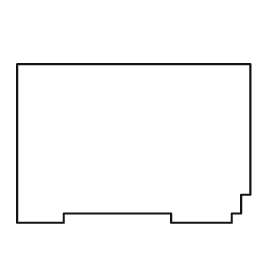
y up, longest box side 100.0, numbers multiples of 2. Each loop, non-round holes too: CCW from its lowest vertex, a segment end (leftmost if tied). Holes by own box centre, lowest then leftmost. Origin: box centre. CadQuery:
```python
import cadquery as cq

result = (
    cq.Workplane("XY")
    .moveTo(-50.0, -34.0)
    .lineTo(-30.0, -34.0)
    .lineTo(-30.0, -30.0)
    .lineTo(16.0, -30.0)
    .lineTo(16.0, -34.0)
    .lineTo(42.0, -34.0)
    .lineTo(42.0, -30.0)
    .lineTo(46.0, -30.0)
    .lineTo(46.0, -22.0)
    .lineTo(50.0, -22.0)
    .lineTo(50.0, 34.0)
    .lineTo(-50.0, 34.0)
    .close()
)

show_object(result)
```